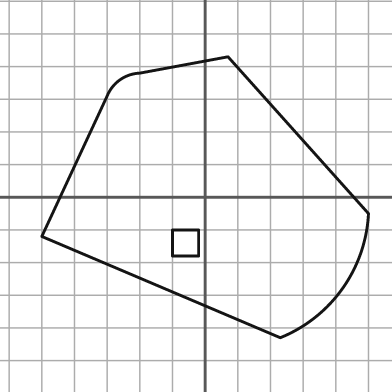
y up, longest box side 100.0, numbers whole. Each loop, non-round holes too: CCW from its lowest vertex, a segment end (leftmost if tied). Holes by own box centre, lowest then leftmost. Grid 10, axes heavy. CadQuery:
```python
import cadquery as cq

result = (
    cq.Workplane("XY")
    .moveTo(23.0, -43.0)
    .threePointArc((42.0, -28.0), (50.0, -5.0))
    .lineTo(7.0, 43.0)
    .lineTo(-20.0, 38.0)
    .threePointArc((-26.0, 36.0), (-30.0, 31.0))
    .lineTo(-50.0, -12.0)
    .close()
    .moveTo(-10.0, -18.0)
    .lineTo(-2.0, -18.0)
    .lineTo(-2.0, -10.0)
    .lineTo(-10.0, -10.0)
    .close()
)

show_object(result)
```